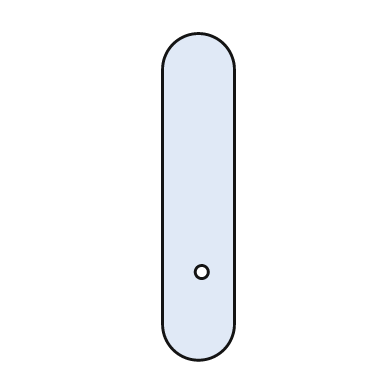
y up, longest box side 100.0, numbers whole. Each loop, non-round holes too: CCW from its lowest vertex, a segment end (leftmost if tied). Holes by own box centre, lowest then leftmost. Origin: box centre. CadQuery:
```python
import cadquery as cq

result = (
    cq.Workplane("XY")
    .moveTo(-11.0, -39.0)
    .threePointArc((0.0, -50.0), (11.0, -39.0))
    .lineTo(11.0, 39.0)
    .threePointArc((0.0, 50.0), (-11.0, 39.0))
    .close()
    .moveTo(1.0, -23.0)
    .circle(2.0)
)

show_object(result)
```